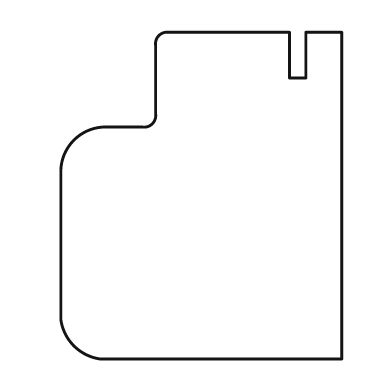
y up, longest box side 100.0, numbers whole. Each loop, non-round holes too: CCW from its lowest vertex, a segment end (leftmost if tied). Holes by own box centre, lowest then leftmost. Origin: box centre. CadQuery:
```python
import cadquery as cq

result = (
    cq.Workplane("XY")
    .moveTo(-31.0, -50.0)
    .lineTo(43.0, -50.0)
    .lineTo(43.0, 50.0)
    .lineTo(32.0, 50.0)
    .lineTo(32.0, 36.0)
    .lineTo(27.0, 36.0)
    .lineTo(27.0, 50.0)
    .lineTo(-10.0, 50.0)
    .threePointArc((-13.0, 49.0), (-14.0, 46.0))
    .lineTo(-14.0, 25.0)
    .threePointArc((-15.0, 22.0), (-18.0, 21.0))
    .lineTo(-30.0, 21.0)
    .threePointArc((-39.0, 17.0), (-43.0, 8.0))
    .lineTo(-43.0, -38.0)
    .threePointArc((-39.0, -46.0), (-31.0, -50.0))
    .close()
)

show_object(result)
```